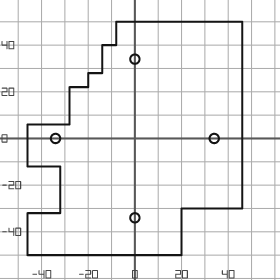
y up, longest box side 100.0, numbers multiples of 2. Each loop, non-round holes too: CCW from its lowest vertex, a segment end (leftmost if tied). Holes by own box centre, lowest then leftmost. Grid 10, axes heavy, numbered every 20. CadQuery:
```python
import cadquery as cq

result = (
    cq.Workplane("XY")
    .moveTo(-46.0, -50.0)
    .lineTo(20.0, -50.0)
    .lineTo(20.0, -30.0)
    .lineTo(46.0, -30.0)
    .lineTo(46.0, 50.0)
    .lineTo(-8.0, 50.0)
    .lineTo(-8.0, 40.0)
    .lineTo(-14.0, 40.0)
    .lineTo(-14.0, 28.0)
    .lineTo(-20.0, 28.0)
    .lineTo(-20.0, 22.0)
    .lineTo(-28.0, 22.0)
    .lineTo(-28.0, 6.0)
    .lineTo(-46.0, 6.0)
    .lineTo(-46.0, -12.0)
    .lineTo(-32.0, -12.0)
    .lineTo(-32.0, -32.0)
    .lineTo(-46.0, -32.0)
    .close()
    .moveTo(0.0, -34.0)
    .circle(2.0)
    .moveTo(-34.0, 0.0)
    .circle(2.0)
    .moveTo(34.0, 0.0)
    .circle(2.0)
    .moveTo(0.0, 34.0)
    .circle(2.0)
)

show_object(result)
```